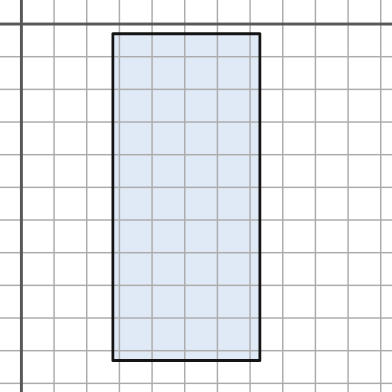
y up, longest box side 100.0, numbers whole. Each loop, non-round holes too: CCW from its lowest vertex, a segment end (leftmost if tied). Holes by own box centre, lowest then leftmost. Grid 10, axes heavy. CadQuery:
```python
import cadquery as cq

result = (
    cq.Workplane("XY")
    .moveTo(28.0, -103.0)
    .lineTo(73.0, -103.0)
    .lineTo(73.0, -3.0)
    .lineTo(28.0, -3.0)
    .close()
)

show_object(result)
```